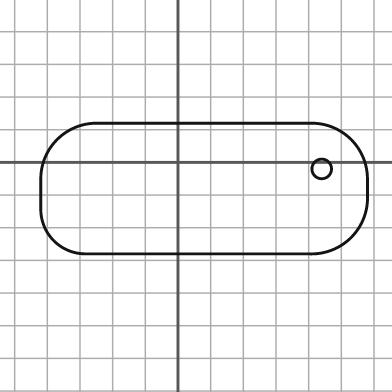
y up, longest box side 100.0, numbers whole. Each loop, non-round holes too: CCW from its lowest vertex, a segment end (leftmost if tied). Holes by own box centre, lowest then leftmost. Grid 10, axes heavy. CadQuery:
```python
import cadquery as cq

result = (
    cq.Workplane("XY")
    .moveTo(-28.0, -28.0)
    .lineTo(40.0, -28.0)
    .threePointArc((53.0, -23.0), (58.0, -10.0))
    .lineTo(58.0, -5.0)
    .threePointArc((53.0, 7.0), (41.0, 12.0))
    .lineTo(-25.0, 12.0)
    .threePointArc((-37.0, 7.0), (-42.0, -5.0))
    .lineTo(-42.0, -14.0)
    .threePointArc((-38.0, -24.0), (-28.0, -28.0))
    .close()
    .moveTo(44.0, -2.0)
    .circle(3.0)
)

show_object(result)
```